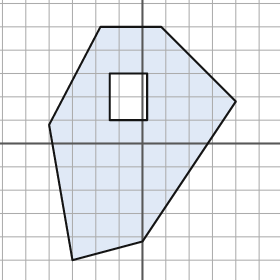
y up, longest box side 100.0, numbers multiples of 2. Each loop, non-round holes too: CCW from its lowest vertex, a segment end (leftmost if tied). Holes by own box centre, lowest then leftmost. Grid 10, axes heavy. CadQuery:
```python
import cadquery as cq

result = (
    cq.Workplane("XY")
    .moveTo(-30.0, -50.0)
    .lineTo(0.0, -42.0)
    .lineTo(40.0, 18.0)
    .lineTo(8.0, 50.0)
    .lineTo(-18.0, 50.0)
    .lineTo(-40.0, 8.0)
    .close()
    .moveTo(-14.0, 10.0)
    .lineTo(2.0, 10.0)
    .lineTo(2.0, 30.0)
    .lineTo(-14.0, 30.0)
    .close()
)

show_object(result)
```